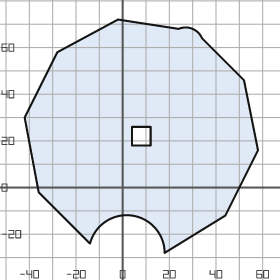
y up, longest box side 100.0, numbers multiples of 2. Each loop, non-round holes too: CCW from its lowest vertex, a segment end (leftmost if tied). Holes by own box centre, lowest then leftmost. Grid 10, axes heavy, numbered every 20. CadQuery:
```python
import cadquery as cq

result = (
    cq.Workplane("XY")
    .moveTo(18.0, -28.0)
    .lineTo(44.0, -12.0)
    .lineTo(58.0, 16.0)
    .lineTo(52.0, 46.0)
    .lineTo(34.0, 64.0)
    .threePointArc((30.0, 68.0), (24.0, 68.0))
    .lineTo(-2.0, 72.0)
    .lineTo(-28.0, 58.0)
    .lineTo(-42.0, 30.0)
    .lineTo(-36.0, -2.0)
    .lineTo(-14.0, -24.0)
    .threePointArc((4.0, -12.0), (18.0, -28.0))
    .close()
    .moveTo(4.0, 18.0)
    .lineTo(12.0, 18.0)
    .lineTo(12.0, 26.0)
    .lineTo(4.0, 26.0)
    .close()
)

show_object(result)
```